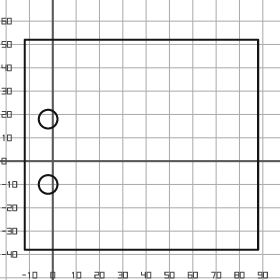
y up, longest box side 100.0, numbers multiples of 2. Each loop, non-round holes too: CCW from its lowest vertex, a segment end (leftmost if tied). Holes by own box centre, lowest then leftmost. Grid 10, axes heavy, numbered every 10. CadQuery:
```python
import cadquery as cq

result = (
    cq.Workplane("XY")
    .moveTo(-12.0, -38.0)
    .lineTo(88.0, -38.0)
    .lineTo(88.0, 52.0)
    .lineTo(-12.0, 52.0)
    .close()
    .moveTo(-2.0, -10.0)
    .circle(4.0)
    .moveTo(-2.0, 18.0)
    .circle(4.0)
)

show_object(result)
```